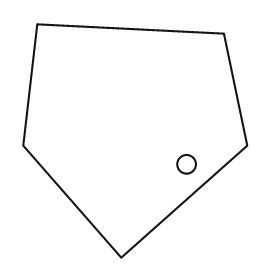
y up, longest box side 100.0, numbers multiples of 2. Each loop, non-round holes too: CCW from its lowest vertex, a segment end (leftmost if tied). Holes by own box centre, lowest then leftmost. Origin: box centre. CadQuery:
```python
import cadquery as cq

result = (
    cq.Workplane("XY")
    .moveTo(-6.0, -50.0)
    .lineTo(48.0, -2.0)
    .lineTo(38.0, 46.0)
    .lineTo(-42.0, 50.0)
    .lineTo(-48.0, -2.0)
    .close()
    .moveTo(22.0, -10.0)
    .circle(4.0)
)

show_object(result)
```